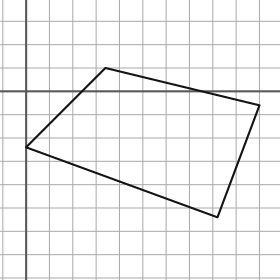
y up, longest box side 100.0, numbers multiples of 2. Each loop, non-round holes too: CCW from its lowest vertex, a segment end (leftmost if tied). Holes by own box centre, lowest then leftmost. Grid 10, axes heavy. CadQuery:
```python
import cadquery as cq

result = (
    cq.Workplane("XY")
    .moveTo(82.0, -54.0)
    .lineTo(100.0, -6.0)
    .lineTo(34.0, 10.0)
    .lineTo(0.0, -24.0)
    .close()
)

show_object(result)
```